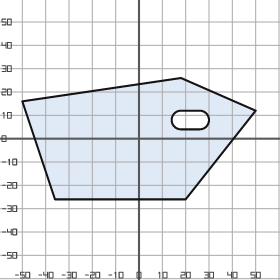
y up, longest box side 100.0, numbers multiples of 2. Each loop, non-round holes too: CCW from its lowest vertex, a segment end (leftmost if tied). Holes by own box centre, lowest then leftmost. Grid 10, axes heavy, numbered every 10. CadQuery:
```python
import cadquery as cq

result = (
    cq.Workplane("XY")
    .moveTo(-36.0, -26.0)
    .lineTo(20.0, -26.0)
    .lineTo(50.0, 12.0)
    .lineTo(18.0, 26.0)
    .lineTo(-50.0, 16.0)
    .close()
    .moveTo(18.0, 4.0)
    .lineTo(26.0, 4.0)
    .threePointArc((30.0, 8.0), (26.0, 12.0))
    .lineTo(18.0, 12.0)
    .threePointArc((14.0, 8.0), (18.0, 4.0))
    .close()
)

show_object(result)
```